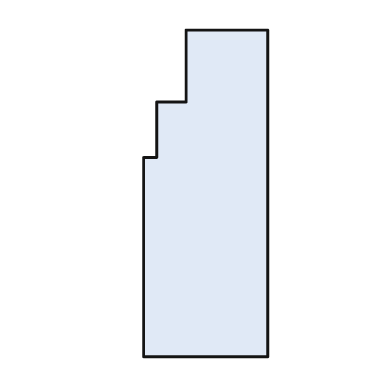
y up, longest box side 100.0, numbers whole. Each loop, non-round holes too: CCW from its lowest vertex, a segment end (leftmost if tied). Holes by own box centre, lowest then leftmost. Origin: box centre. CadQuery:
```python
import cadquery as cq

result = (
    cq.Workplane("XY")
    .moveTo(-19.0, -50.0)
    .lineTo(19.0, -50.0)
    .lineTo(19.0, 50.0)
    .lineTo(-6.0, 50.0)
    .lineTo(-6.0, 28.0)
    .lineTo(-15.0, 28.0)
    .lineTo(-15.0, 11.0)
    .lineTo(-19.0, 11.0)
    .close()
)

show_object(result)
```